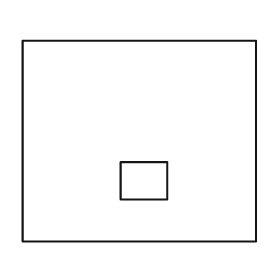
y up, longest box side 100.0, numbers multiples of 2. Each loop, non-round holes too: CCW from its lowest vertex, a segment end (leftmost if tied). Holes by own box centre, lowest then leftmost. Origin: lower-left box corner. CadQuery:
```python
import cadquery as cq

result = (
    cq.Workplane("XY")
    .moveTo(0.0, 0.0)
    .lineTo(100.0, 0.0)
    .lineTo(100.0, 86.0)
    .lineTo(0.0, 86.0)
    .close()
    .moveTo(42.0, 18.0)
    .lineTo(62.0, 18.0)
    .lineTo(62.0, 34.0)
    .lineTo(42.0, 34.0)
    .close()
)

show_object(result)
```